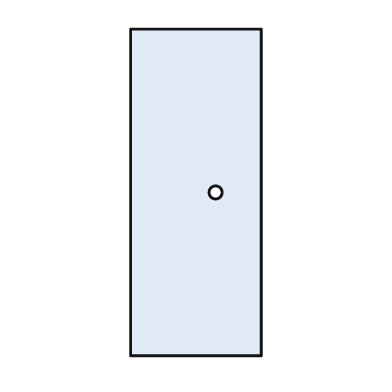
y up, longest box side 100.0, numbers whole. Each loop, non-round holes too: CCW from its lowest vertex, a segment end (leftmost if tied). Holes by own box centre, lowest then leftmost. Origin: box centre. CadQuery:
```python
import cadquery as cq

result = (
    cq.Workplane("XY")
    .moveTo(-20.0, -50.0)
    .lineTo(20.0, -50.0)
    .lineTo(20.0, 50.0)
    .lineTo(-20.0, 50.0)
    .close()
    .moveTo(6.0, 0.0)
    .circle(2.0)
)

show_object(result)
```